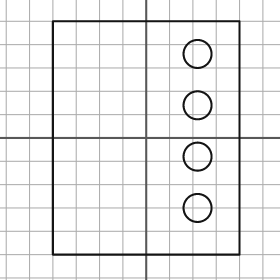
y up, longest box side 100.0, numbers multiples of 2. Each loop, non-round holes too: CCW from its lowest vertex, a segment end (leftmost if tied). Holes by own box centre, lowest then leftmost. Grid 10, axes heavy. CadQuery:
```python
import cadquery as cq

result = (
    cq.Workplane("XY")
    .moveTo(-40.0, -50.0)
    .lineTo(40.0, -50.0)
    .lineTo(40.0, 50.0)
    .lineTo(-40.0, 50.0)
    .close()
    .moveTo(22.0, -30.0)
    .circle(6.0)
    .moveTo(22.0, -8.0)
    .circle(6.0)
    .moveTo(22.0, 14.0)
    .circle(6.0)
    .moveTo(22.0, 36.0)
    .circle(6.0)
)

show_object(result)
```